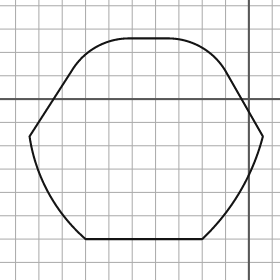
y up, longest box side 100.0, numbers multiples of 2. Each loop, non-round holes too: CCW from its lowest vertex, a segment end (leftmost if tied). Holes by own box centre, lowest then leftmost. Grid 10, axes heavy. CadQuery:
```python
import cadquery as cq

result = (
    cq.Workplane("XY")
    .moveTo(-70.0, -60.0)
    .lineTo(-20.0, -60.0)
    .threePointArc((-4.0, -40.0), (6.0, -16.0))
    .lineTo(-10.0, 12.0)
    .threePointArc((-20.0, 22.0), (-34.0, 26.0))
    .lineTo(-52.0, 26.0)
    .threePointArc((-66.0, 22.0), (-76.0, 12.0))
    .lineTo(-94.0, -16.0)
    .threePointArc((-86.0, -40.0), (-70.0, -60.0))
    .close()
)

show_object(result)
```